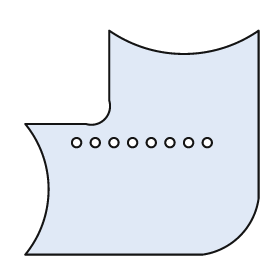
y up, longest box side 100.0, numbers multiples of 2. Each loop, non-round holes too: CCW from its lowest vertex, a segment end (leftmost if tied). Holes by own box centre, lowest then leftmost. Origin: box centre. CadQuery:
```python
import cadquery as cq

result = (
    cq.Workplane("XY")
    .moveTo(-50.0, -48.0)
    .lineTo(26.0, -48.0)
    .threePointArc((42.0, -40.0), (50.0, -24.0))
    .lineTo(50.0, 48.0)
    .threePointArc((18.0, 38.0), (-14.0, 48.0))
    .lineTo(-14.0, 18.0)
    .threePointArc((-16.0, 10.0), (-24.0, 8.0))
    .lineTo(-50.0, 8.0)
    .threePointArc((-40.0, -20.0), (-50.0, -48.0))
    .close()
    .moveTo(-28.0, 0.0)
    .circle(2.0)
    .moveTo(-20.0, 0.0)
    .circle(2.0)
    .moveTo(-12.0, 0.0)
    .circle(2.0)
    .moveTo(-4.0, 0.0)
    .circle(2.0)
    .moveTo(4.0, 0.0)
    .circle(2.0)
    .moveTo(12.0, 0.0)
    .circle(2.0)
    .moveTo(20.0, 0.0)
    .circle(2.0)
    .moveTo(28.0, 0.0)
    .circle(2.0)
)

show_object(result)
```